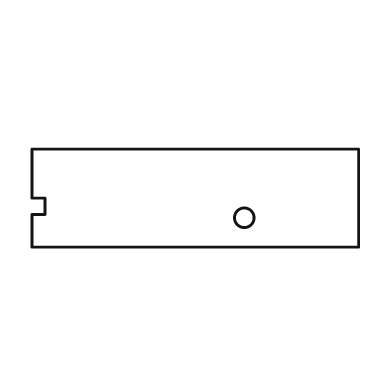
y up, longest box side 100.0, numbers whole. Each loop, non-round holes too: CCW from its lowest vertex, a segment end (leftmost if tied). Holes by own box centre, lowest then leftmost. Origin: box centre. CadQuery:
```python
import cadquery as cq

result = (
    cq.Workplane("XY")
    .moveTo(-50.0, -15.0)
    .lineTo(50.0, -15.0)
    .lineTo(50.0, 15.0)
    .lineTo(-50.0, 15.0)
    .lineTo(-50.0, 0.0)
    .lineTo(-46.0, 0.0)
    .lineTo(-46.0, -5.0)
    .lineTo(-50.0, -5.0)
    .close()
    .moveTo(15.0, -6.0)
    .circle(3.0)
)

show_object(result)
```